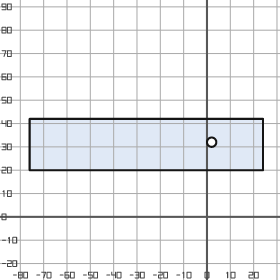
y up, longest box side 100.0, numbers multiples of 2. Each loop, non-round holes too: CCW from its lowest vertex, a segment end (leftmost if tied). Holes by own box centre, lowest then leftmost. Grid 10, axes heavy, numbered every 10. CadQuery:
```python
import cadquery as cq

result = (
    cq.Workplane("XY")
    .moveTo(-76.0, 20.0)
    .lineTo(24.0, 20.0)
    .lineTo(24.0, 42.0)
    .lineTo(-76.0, 42.0)
    .close()
    .moveTo(2.0, 32.0)
    .circle(2.0)
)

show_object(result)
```